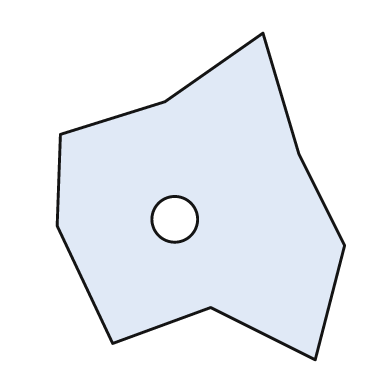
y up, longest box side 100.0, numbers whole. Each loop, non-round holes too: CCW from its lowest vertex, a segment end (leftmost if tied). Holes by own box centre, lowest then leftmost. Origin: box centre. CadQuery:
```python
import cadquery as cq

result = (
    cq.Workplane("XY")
    .moveTo(35.0, -50.0)
    .lineTo(44.0, -15.0)
    .lineTo(30.0, 13.0)
    .lineTo(19.0, 50.0)
    .lineTo(-11.0, 29.0)
    .lineTo(-43.0, 19.0)
    .lineTo(-44.0, -9.0)
    .lineTo(-27.0, -45.0)
    .lineTo(3.0, -34.0)
    .close()
    .moveTo(-8.0, -7.0)
    .circle(7.0)
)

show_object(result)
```